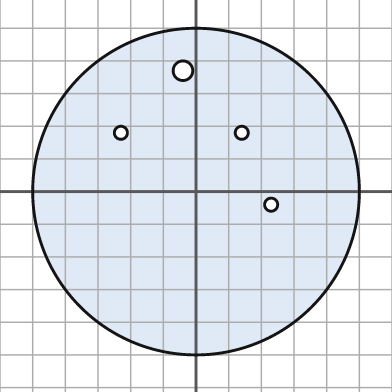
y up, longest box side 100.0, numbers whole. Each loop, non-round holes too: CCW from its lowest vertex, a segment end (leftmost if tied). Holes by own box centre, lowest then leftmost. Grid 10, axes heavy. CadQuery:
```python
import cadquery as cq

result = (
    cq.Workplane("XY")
    .moveTo(0.0, 0.0)
    .circle(50.0)
    .moveTo(23.0, -4.0)
    .circle(2.0)
    .moveTo(-23.0, 18.0)
    .circle(2.0)
    .moveTo(14.0, 18.0)
    .circle(2.0)
    .moveTo(-4.0, 37.0)
    .circle(3.0)
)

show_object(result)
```